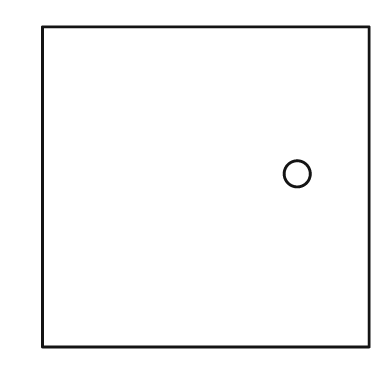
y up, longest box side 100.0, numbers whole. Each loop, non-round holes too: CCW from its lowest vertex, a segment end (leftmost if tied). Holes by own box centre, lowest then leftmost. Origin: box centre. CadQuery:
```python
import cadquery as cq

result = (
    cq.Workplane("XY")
    .moveTo(-50.0, -49.0)
    .lineTo(50.0, -49.0)
    .lineTo(50.0, 49.0)
    .lineTo(-50.0, 49.0)
    .close()
    .moveTo(28.0, 4.0)
    .circle(4.0)
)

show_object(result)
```